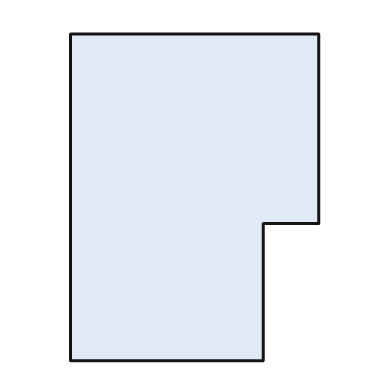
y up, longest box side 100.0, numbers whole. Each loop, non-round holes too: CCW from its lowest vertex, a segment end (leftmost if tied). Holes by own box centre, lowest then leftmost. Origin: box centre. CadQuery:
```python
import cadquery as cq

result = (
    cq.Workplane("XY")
    .moveTo(-38.0, -50.0)
    .lineTo(21.0, -50.0)
    .lineTo(21.0, -8.0)
    .lineTo(38.0, -8.0)
    .lineTo(38.0, 50.0)
    .lineTo(-38.0, 50.0)
    .close()
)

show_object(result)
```